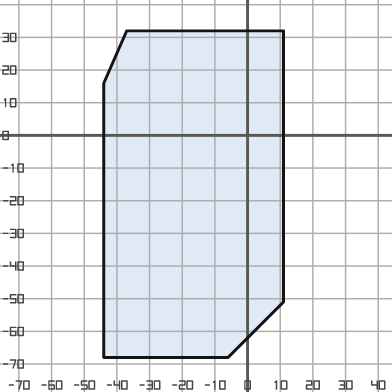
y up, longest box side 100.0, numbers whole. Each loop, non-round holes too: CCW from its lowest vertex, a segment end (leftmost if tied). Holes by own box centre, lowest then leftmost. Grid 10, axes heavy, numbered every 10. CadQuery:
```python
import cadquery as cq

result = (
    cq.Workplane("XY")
    .moveTo(-44.0, -68.0)
    .lineTo(-6.0, -68.0)
    .lineTo(11.0, -51.0)
    .lineTo(11.0, 32.0)
    .lineTo(-37.0, 32.0)
    .lineTo(-44.0, 16.0)
    .close()
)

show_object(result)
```